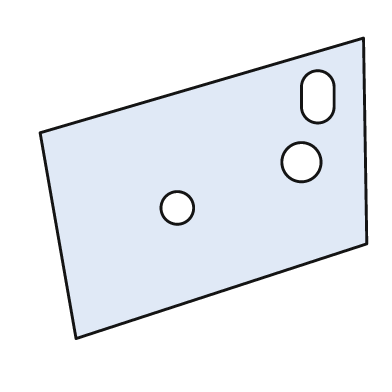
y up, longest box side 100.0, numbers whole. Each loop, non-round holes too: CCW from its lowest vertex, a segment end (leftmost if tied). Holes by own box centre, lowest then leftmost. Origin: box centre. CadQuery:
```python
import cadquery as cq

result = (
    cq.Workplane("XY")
    .moveTo(-39.0, -46.0)
    .lineTo(50.0, -17.0)
    .lineTo(49.0, 46.0)
    .lineTo(-50.0, 17.0)
    .close()
    .moveTo(-8.0, -6.0)
    .circle(5.0)
    .moveTo(30.0, 8.0)
    .circle(6.0)
    .moveTo(30.0, 25.0)
    .threePointArc((35.0, 20.0), (40.0, 25.0))
    .lineTo(40.0, 31.0)
    .threePointArc((35.0, 36.0), (30.0, 31.0))
    .close()
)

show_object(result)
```